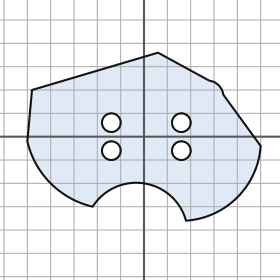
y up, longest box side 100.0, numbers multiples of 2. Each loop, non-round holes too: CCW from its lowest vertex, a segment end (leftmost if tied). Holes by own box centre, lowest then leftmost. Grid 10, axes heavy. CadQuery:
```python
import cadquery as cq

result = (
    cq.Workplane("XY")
    .moveTo(18.0, -36.0)
    .threePointArc((40.0, -26.0), (50.0, -4.0))
    .lineTo(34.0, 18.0)
    .threePointArc((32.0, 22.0), (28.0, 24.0))
    .lineTo(6.0, 36.0)
    .lineTo(-48.0, 20.0)
    .lineTo(-50.0, -2.0)
    .threePointArc((-40.0, -20.0), (-22.0, -30.0))
    .threePointArc((0.0, -20.0), (18.0, -36.0))
    .close()
    .moveTo(-14.0, -6.0)
    .circle(4.0)
    .moveTo(16.0, -6.0)
    .circle(4.0)
    .moveTo(-14.0, 6.0)
    .circle(4.0)
    .moveTo(16.0, 6.0)
    .circle(4.0)
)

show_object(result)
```